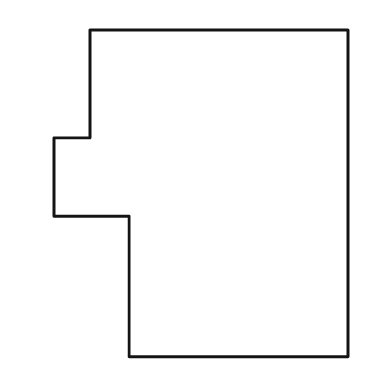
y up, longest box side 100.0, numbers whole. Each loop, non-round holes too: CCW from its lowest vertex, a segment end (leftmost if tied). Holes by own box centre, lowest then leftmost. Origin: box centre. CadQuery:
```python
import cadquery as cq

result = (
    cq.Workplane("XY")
    .moveTo(-22.0, -50.0)
    .lineTo(45.0, -50.0)
    .lineTo(45.0, 50.0)
    .lineTo(-34.0, 50.0)
    .lineTo(-34.0, 17.0)
    .lineTo(-45.0, 17.0)
    .lineTo(-45.0, -7.0)
    .lineTo(-22.0, -7.0)
    .close()
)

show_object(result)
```